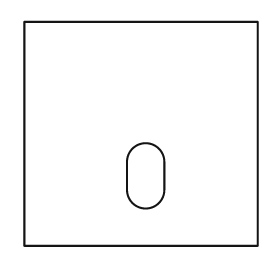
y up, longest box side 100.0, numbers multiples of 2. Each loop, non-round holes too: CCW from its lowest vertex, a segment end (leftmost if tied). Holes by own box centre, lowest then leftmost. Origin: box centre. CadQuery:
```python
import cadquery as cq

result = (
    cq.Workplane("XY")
    .moveTo(-50.0, -48.0)
    .lineTo(50.0, -48.0)
    .lineTo(50.0, 48.0)
    .lineTo(-50.0, 48.0)
    .close()
    .moveTo(-6.0, -24.0)
    .threePointArc((2.0, -32.0), (10.0, -24.0))
    .lineTo(10.0, -12.0)
    .threePointArc((2.0, -4.0), (-6.0, -12.0))
    .close()
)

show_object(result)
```